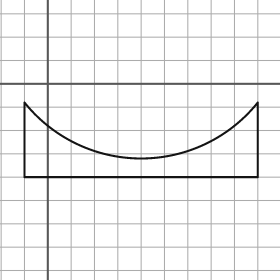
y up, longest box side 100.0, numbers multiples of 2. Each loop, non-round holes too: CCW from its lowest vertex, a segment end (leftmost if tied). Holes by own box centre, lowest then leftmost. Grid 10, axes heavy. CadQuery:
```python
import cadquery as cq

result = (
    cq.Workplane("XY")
    .moveTo(-10.0, -40.0)
    .lineTo(90.0, -40.0)
    .lineTo(90.0, -8.0)
    .threePointArc((40.0, -32.0), (-10.0, -8.0))
    .close()
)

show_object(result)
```